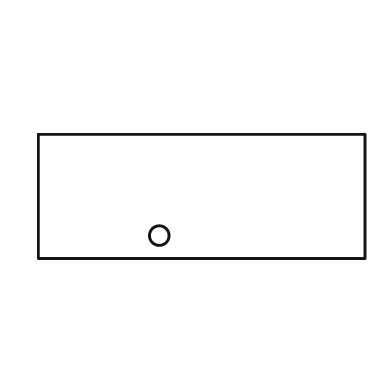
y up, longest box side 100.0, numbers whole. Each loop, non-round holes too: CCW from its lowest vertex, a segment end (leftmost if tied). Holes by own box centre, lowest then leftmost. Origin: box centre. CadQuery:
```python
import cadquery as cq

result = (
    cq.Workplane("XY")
    .moveTo(-50.0, -19.0)
    .lineTo(50.0, -19.0)
    .lineTo(50.0, 19.0)
    .lineTo(-50.0, 19.0)
    .close()
    .moveTo(-13.0, -12.0)
    .circle(3.0)
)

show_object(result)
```